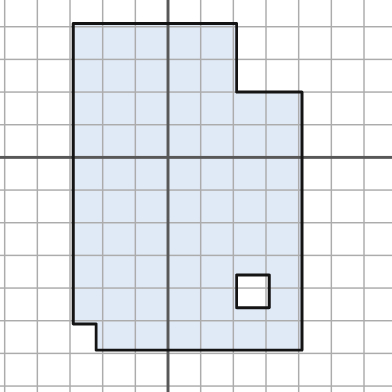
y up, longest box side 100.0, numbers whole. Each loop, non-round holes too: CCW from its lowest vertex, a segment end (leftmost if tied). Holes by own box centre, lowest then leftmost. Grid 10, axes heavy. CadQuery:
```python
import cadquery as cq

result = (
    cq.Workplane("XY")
    .moveTo(-22.0, -59.0)
    .lineTo(41.0, -59.0)
    .lineTo(41.0, 20.0)
    .lineTo(21.0, 20.0)
    .lineTo(21.0, 41.0)
    .lineTo(-29.0, 41.0)
    .lineTo(-29.0, -51.0)
    .lineTo(-22.0, -51.0)
    .close()
    .moveTo(21.0, -46.0)
    .lineTo(31.0, -46.0)
    .lineTo(31.0, -36.0)
    .lineTo(21.0, -36.0)
    .close()
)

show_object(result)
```